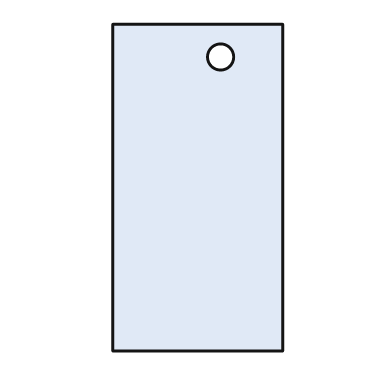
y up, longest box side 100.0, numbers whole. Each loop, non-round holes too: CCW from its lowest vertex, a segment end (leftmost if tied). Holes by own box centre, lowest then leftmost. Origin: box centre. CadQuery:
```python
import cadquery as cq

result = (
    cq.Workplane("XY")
    .moveTo(-26.0, -50.0)
    .lineTo(26.0, -50.0)
    .lineTo(26.0, 50.0)
    .lineTo(-26.0, 50.0)
    .close()
    .moveTo(7.0, 40.0)
    .circle(4.0)
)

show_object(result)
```